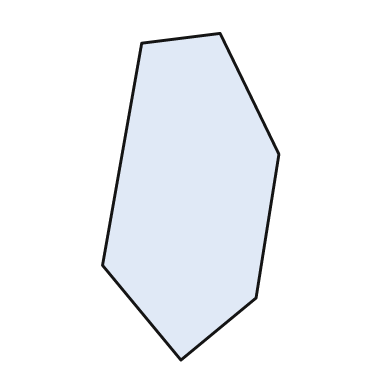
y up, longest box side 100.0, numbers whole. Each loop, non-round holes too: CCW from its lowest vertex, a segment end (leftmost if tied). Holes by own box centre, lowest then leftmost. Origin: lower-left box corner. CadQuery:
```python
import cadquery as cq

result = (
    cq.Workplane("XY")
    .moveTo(24.0, 0.0)
    .lineTo(47.0, 19.0)
    .lineTo(54.0, 63.0)
    .lineTo(36.0, 100.0)
    .lineTo(12.0, 97.0)
    .lineTo(0.0, 29.0)
    .close()
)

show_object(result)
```